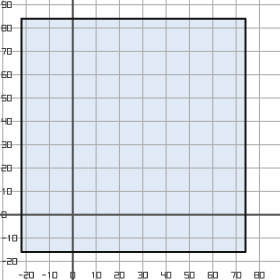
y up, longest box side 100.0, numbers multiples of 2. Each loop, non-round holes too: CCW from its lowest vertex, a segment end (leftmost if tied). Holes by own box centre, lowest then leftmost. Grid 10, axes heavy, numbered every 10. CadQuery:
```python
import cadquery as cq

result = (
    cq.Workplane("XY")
    .moveTo(-22.0, -16.0)
    .lineTo(74.0, -16.0)
    .lineTo(74.0, 84.0)
    .lineTo(-22.0, 84.0)
    .close()
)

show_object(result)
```